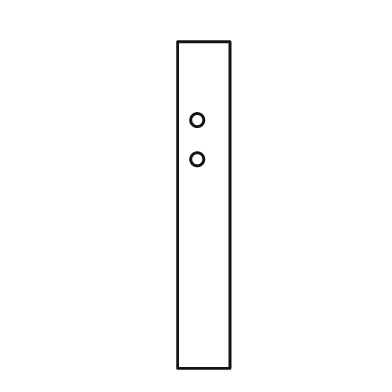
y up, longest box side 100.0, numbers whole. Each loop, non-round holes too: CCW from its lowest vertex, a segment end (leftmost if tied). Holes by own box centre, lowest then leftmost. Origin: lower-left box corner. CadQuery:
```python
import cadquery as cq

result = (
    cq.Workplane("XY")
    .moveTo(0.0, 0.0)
    .lineTo(16.0, 0.0)
    .lineTo(16.0, 100.0)
    .lineTo(0.0, 100.0)
    .close()
    .moveTo(6.0, 64.0)
    .circle(2.0)
    .moveTo(6.0, 76.0)
    .circle(2.0)
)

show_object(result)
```